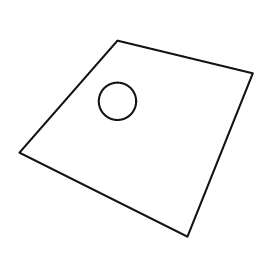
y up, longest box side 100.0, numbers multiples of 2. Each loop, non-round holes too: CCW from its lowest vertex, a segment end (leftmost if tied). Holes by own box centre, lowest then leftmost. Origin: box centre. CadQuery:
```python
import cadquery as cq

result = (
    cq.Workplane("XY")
    .moveTo(22.0, -42.0)
    .lineTo(50.0, 28.0)
    .lineTo(-8.0, 42.0)
    .lineTo(-50.0, -6.0)
    .close()
    .moveTo(-8.0, 16.0)
    .circle(8.0)
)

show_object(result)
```